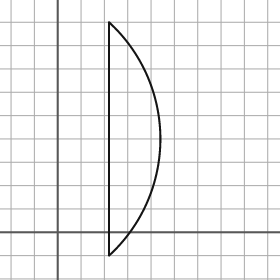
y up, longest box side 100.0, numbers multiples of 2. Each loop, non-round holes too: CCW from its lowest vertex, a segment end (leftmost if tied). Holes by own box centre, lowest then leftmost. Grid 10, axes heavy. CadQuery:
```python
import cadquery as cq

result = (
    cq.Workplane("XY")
    .moveTo(22.0, -10.0)
    .threePointArc((44.0, 40.0), (22.0, 90.0))
    .close()
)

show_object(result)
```